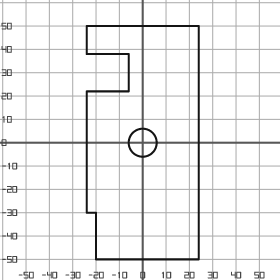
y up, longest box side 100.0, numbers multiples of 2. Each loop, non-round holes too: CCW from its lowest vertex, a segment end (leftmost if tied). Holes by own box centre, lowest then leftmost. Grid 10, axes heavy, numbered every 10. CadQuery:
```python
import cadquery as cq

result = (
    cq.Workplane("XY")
    .moveTo(-20.0, -50.0)
    .lineTo(24.0, -50.0)
    .lineTo(24.0, 50.0)
    .lineTo(-24.0, 50.0)
    .lineTo(-24.0, 38.0)
    .lineTo(-6.0, 38.0)
    .lineTo(-6.0, 22.0)
    .lineTo(-24.0, 22.0)
    .lineTo(-24.0, -30.0)
    .lineTo(-20.0, -30.0)
    .close()
    .moveTo(0.0, 0.0)
    .circle(6.0)
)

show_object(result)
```